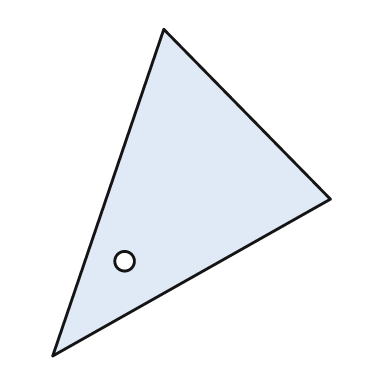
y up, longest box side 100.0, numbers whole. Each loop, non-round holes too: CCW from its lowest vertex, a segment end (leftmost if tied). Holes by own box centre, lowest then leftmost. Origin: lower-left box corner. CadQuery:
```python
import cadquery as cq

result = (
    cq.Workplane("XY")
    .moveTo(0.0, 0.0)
    .lineTo(85.0, 48.0)
    .lineTo(34.0, 100.0)
    .close()
    .moveTo(22.0, 29.0)
    .circle(3.0)
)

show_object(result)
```